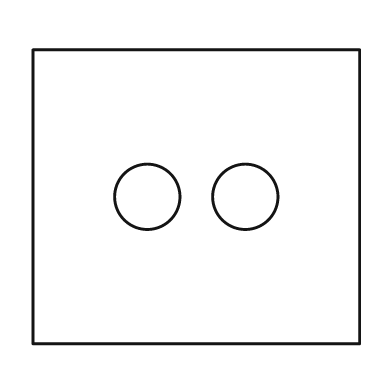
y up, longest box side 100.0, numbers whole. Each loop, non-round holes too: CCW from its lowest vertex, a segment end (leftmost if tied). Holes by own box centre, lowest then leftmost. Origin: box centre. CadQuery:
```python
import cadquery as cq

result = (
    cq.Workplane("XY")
    .moveTo(-50.0, -45.0)
    .lineTo(50.0, -45.0)
    .lineTo(50.0, 45.0)
    .lineTo(-50.0, 45.0)
    .close()
    .moveTo(-15.0, 0.0)
    .circle(10.0)
    .moveTo(15.0, 0.0)
    .circle(10.0)
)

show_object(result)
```